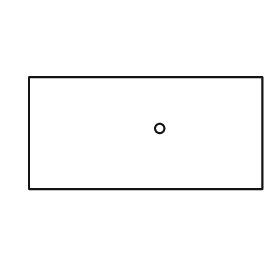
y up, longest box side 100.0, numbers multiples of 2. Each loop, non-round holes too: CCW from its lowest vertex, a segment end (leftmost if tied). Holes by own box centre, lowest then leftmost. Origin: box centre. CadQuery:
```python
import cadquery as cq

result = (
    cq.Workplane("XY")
    .moveTo(-50.0, -24.0)
    .lineTo(50.0, -24.0)
    .lineTo(50.0, 24.0)
    .lineTo(-50.0, 24.0)
    .close()
    .moveTo(6.0, 2.0)
    .circle(2.0)
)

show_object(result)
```